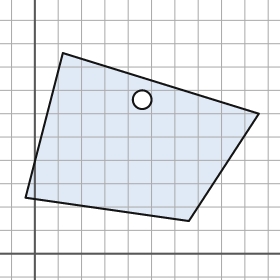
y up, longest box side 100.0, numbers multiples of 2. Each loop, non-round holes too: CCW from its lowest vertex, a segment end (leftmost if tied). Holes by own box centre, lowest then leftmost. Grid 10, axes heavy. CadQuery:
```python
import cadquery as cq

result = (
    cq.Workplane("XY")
    .moveTo(66.0, 14.0)
    .lineTo(96.0, 60.0)
    .lineTo(12.0, 86.0)
    .lineTo(-4.0, 24.0)
    .close()
    .moveTo(46.0, 66.0)
    .circle(4.0)
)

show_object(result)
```